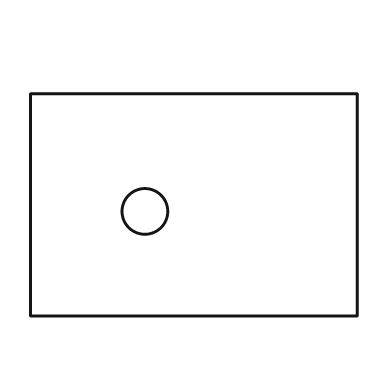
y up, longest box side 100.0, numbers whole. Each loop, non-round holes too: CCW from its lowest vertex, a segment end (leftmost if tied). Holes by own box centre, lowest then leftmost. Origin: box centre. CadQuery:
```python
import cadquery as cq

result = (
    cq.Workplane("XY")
    .moveTo(-50.0, -34.0)
    .lineTo(50.0, -34.0)
    .lineTo(50.0, 34.0)
    .lineTo(-50.0, 34.0)
    .close()
    .moveTo(-15.0, -2.0)
    .circle(7.0)
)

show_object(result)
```